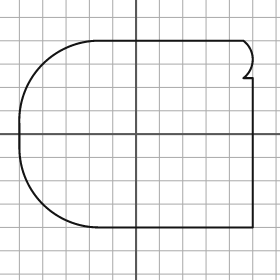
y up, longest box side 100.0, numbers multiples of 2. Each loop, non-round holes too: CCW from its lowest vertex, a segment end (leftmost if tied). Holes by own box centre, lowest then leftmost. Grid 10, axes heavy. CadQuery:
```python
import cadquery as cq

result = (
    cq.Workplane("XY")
    .moveTo(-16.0, -40.0)
    .lineTo(50.0, -40.0)
    .lineTo(50.0, 24.0)
    .lineTo(46.0, 24.0)
    .threePointArc((50.0, 32.0), (46.0, 40.0))
    .lineTo(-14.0, 40.0)
    .threePointArc((-40.0, 30.0), (-50.0, 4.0))
    .lineTo(-50.0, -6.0)
    .threePointArc((-40.0, -30.0), (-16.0, -40.0))
    .close()
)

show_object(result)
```